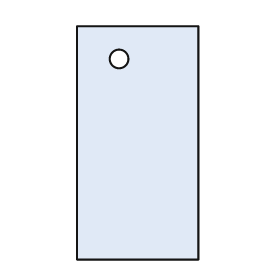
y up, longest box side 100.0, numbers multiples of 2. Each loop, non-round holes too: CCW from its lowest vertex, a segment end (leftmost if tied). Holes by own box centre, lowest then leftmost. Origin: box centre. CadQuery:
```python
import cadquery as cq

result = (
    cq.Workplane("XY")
    .moveTo(-26.0, -50.0)
    .lineTo(26.0, -50.0)
    .lineTo(26.0, 50.0)
    .lineTo(-26.0, 50.0)
    .close()
    .moveTo(-8.0, 36.0)
    .circle(4.0)
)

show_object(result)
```